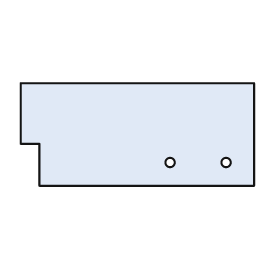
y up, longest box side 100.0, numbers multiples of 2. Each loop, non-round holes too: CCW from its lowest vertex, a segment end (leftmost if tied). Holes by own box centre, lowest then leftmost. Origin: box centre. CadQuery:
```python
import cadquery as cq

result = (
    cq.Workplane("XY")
    .moveTo(-42.0, -22.0)
    .lineTo(50.0, -22.0)
    .lineTo(50.0, 22.0)
    .lineTo(-50.0, 22.0)
    .lineTo(-50.0, -4.0)
    .lineTo(-42.0, -4.0)
    .close()
    .moveTo(14.0, -12.0)
    .circle(2.0)
    .moveTo(38.0, -12.0)
    .circle(2.0)
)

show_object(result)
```